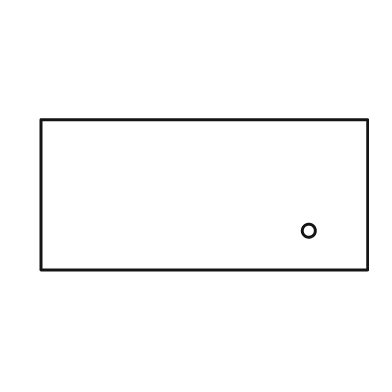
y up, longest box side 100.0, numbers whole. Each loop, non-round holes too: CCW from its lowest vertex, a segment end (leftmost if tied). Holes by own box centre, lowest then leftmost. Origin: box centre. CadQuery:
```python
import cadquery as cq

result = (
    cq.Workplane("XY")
    .moveTo(-50.0, -23.0)
    .lineTo(50.0, -23.0)
    .lineTo(50.0, 23.0)
    .lineTo(-50.0, 23.0)
    .close()
    .moveTo(32.0, -11.0)
    .circle(2.0)
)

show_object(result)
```